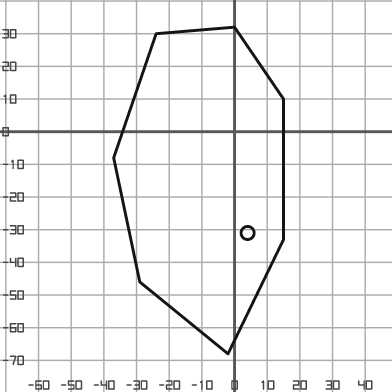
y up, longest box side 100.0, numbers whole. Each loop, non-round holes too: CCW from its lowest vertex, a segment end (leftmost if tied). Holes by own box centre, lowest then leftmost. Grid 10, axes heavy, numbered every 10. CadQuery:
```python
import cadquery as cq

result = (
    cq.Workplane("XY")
    .moveTo(-2.0, -68.0)
    .lineTo(15.0, -33.0)
    .lineTo(15.0, 10.0)
    .lineTo(0.0, 32.0)
    .lineTo(-24.0, 30.0)
    .lineTo(-37.0, -8.0)
    .lineTo(-29.0, -46.0)
    .close()
    .moveTo(4.0, -31.0)
    .circle(2.0)
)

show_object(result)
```